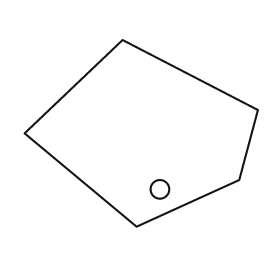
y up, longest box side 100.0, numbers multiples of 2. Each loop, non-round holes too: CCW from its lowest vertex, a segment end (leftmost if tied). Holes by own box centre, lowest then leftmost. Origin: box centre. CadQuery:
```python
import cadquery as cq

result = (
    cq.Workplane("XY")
    .moveTo(-2.0, -40.0)
    .lineTo(42.0, -20.0)
    .lineTo(50.0, 10.0)
    .lineTo(-8.0, 40.0)
    .lineTo(-50.0, 0.0)
    .close()
    .moveTo(8.0, -24.0)
    .circle(4.0)
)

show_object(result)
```